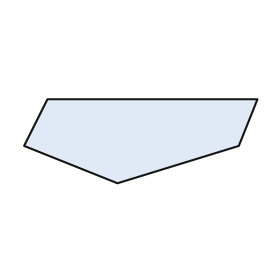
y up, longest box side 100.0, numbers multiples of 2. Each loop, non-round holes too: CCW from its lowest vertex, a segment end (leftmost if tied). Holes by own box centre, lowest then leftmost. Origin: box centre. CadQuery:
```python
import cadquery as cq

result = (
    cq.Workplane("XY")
    .moveTo(-10.0, -18.0)
    .lineTo(42.0, -2.0)
    .lineTo(50.0, 18.0)
    .lineTo(-40.0, 18.0)
    .lineTo(-50.0, -2.0)
    .close()
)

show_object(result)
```